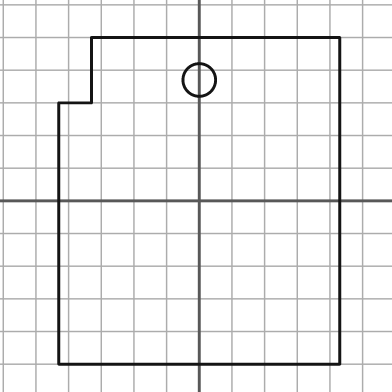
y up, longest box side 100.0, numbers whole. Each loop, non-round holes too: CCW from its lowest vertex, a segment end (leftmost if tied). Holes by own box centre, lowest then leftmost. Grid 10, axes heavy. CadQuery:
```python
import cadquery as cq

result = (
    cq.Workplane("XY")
    .moveTo(-43.0, -50.0)
    .lineTo(43.0, -50.0)
    .lineTo(43.0, 50.0)
    .lineTo(-33.0, 50.0)
    .lineTo(-33.0, 30.0)
    .lineTo(-43.0, 30.0)
    .close()
    .moveTo(0.0, 37.0)
    .circle(5.0)
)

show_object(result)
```